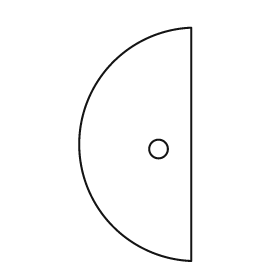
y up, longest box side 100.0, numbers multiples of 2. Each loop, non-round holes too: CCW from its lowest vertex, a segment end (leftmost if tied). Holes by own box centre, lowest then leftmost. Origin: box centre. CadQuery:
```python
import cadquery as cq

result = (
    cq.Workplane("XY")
    .moveTo(24.0, -50.0)
    .lineTo(24.0, 50.0)
    .threePointArc((-24.0, 0.0), (24.0, -50.0))
    .close()
    .moveTo(10.0, -2.0)
    .circle(4.0)
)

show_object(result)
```